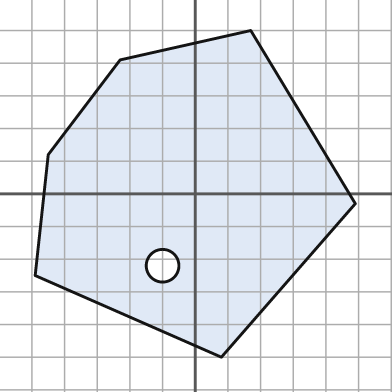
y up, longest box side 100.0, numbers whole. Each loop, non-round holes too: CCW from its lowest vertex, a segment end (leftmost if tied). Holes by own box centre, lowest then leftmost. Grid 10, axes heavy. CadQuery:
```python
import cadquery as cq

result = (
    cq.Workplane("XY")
    .moveTo(8.0, -50.0)
    .lineTo(49.0, -3.0)
    .lineTo(17.0, 50.0)
    .lineTo(-23.0, 41.0)
    .lineTo(-45.0, 12.0)
    .lineTo(-49.0, -25.0)
    .close()
    .moveTo(-10.0, -22.0)
    .circle(5.0)
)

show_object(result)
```